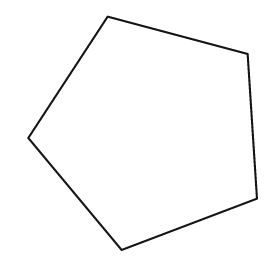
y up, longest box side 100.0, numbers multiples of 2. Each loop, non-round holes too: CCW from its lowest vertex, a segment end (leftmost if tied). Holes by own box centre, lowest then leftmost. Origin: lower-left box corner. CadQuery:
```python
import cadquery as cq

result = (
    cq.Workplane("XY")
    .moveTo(40.0, 0.0)
    .lineTo(98.0, 22.0)
    .lineTo(94.0, 84.0)
    .lineTo(34.0, 100.0)
    .lineTo(0.0, 48.0)
    .close()
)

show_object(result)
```